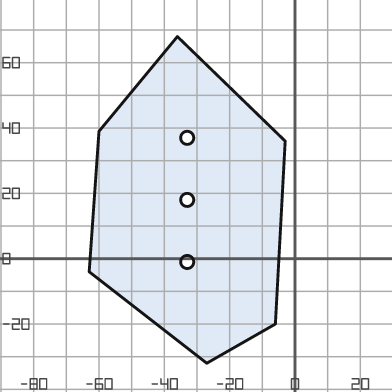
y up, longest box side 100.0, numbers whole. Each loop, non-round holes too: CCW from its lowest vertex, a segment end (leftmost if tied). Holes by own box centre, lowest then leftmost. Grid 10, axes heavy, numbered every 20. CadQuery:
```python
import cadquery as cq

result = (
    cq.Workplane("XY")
    .moveTo(-27.0, -32.0)
    .lineTo(-6.0, -20.0)
    .lineTo(-3.0, 36.0)
    .lineTo(-36.0, 68.0)
    .lineTo(-60.0, 39.0)
    .lineTo(-63.0, -4.0)
    .close()
    .moveTo(-33.0, -1.0)
    .circle(2.0)
    .moveTo(-33.0, 18.0)
    .circle(2.0)
    .moveTo(-33.0, 37.0)
    .circle(2.0)
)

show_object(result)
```